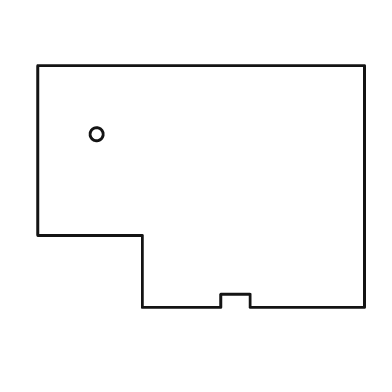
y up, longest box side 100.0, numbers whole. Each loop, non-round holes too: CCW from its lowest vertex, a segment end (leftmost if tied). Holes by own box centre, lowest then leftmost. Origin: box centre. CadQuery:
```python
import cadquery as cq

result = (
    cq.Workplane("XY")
    .moveTo(-18.0, -37.0)
    .lineTo(6.0, -37.0)
    .lineTo(6.0, -33.0)
    .lineTo(15.0, -33.0)
    .lineTo(15.0, -37.0)
    .lineTo(50.0, -37.0)
    .lineTo(50.0, 37.0)
    .lineTo(-50.0, 37.0)
    .lineTo(-50.0, -15.0)
    .lineTo(-18.0, -15.0)
    .close()
    .moveTo(-32.0, 16.0)
    .circle(2.0)
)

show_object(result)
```